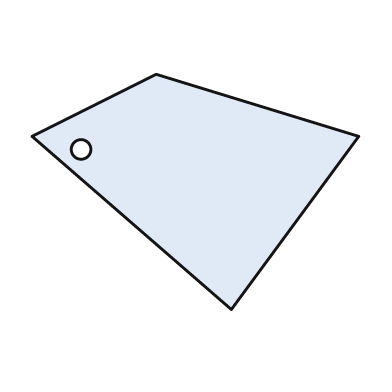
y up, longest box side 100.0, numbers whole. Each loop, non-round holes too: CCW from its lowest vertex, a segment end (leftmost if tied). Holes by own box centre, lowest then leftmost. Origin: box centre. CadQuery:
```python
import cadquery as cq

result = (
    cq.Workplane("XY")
    .moveTo(11.0, -36.0)
    .lineTo(50.0, 17.0)
    .lineTo(-12.0, 36.0)
    .lineTo(-50.0, 17.0)
    .close()
    .moveTo(-35.0, 13.0)
    .circle(3.0)
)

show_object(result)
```